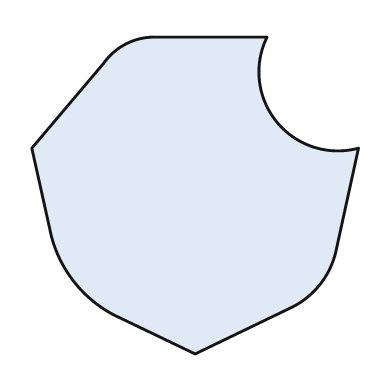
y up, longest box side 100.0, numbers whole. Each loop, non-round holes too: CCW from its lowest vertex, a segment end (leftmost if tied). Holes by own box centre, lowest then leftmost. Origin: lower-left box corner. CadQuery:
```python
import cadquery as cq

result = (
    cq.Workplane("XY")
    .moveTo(50.0, 0.0)
    .lineTo(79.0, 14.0)
    .threePointArc((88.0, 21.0), (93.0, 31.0))
    .lineTo(100.0, 63.0)
    .threePointArc((75.0, 71.0), (72.0, 97.0))
    .lineTo(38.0, 97.0)
    .threePointArc((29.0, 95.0), (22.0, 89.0))
    .lineTo(0.0, 63.0)
    .lineTo(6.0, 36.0)
    .threePointArc((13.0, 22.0), (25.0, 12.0))
    .close()
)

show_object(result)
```